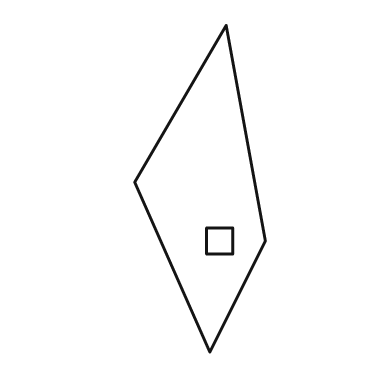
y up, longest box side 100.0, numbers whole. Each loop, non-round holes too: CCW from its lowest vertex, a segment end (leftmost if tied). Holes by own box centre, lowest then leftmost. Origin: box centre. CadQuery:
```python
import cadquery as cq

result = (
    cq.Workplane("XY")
    .moveTo(3.0, -50.0)
    .lineTo(20.0, -16.0)
    .lineTo(8.0, 50.0)
    .lineTo(-20.0, 2.0)
    .close()
    .moveTo(2.0, -20.0)
    .lineTo(10.0, -20.0)
    .lineTo(10.0, -12.0)
    .lineTo(2.0, -12.0)
    .close()
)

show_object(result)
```